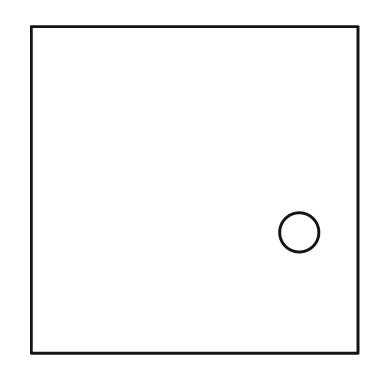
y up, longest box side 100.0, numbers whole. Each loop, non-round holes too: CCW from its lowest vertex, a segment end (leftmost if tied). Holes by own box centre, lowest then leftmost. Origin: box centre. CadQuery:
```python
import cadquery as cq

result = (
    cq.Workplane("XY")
    .moveTo(-50.0, -50.0)
    .lineTo(50.0, -50.0)
    .lineTo(50.0, 50.0)
    .lineTo(-50.0, 50.0)
    .close()
    .moveTo(32.0, -13.0)
    .circle(6.0)
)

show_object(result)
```